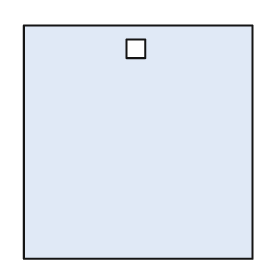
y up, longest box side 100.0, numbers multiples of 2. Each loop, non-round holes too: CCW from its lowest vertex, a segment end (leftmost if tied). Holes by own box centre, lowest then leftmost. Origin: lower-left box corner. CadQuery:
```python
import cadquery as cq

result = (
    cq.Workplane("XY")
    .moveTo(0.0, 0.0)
    .lineTo(98.0, 0.0)
    .lineTo(98.0, 100.0)
    .lineTo(0.0, 100.0)
    .close()
    .moveTo(44.0, 86.0)
    .lineTo(52.0, 86.0)
    .lineTo(52.0, 94.0)
    .lineTo(44.0, 94.0)
    .close()
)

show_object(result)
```